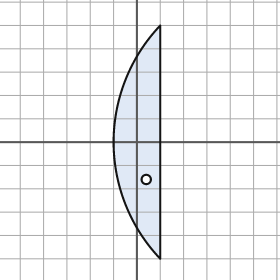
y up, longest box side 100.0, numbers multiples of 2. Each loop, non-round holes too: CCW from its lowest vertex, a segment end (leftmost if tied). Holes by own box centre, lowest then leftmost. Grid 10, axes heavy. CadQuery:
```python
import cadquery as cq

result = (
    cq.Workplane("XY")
    .moveTo(10.0, -50.0)
    .lineTo(10.0, 50.0)
    .threePointArc((-10.0, 0.0), (10.0, -50.0))
    .close()
    .moveTo(4.0, -16.0)
    .circle(2.0)
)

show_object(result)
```